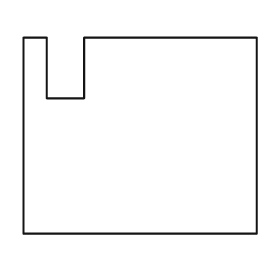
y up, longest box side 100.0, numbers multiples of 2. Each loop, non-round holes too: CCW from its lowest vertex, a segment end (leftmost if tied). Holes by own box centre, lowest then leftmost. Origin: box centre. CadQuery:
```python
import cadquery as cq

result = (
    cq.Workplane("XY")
    .moveTo(-50.0, -42.0)
    .lineTo(50.0, -42.0)
    .lineTo(50.0, 42.0)
    .lineTo(-24.0, 42.0)
    .lineTo(-24.0, 16.0)
    .lineTo(-40.0, 16.0)
    .lineTo(-40.0, 42.0)
    .lineTo(-50.0, 42.0)
    .close()
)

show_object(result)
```